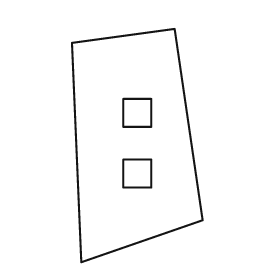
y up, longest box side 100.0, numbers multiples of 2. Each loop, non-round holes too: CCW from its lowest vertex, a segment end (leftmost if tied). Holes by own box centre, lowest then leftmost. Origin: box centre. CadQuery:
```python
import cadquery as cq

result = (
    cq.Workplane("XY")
    .moveTo(-24.0, -50.0)
    .lineTo(28.0, -32.0)
    .lineTo(16.0, 50.0)
    .lineTo(-28.0, 44.0)
    .close()
    .moveTo(-6.0, -18.0)
    .lineTo(6.0, -18.0)
    .lineTo(6.0, -6.0)
    .lineTo(-6.0, -6.0)
    .close()
    .moveTo(-6.0, 8.0)
    .lineTo(6.0, 8.0)
    .lineTo(6.0, 20.0)
    .lineTo(-6.0, 20.0)
    .close()
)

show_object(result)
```